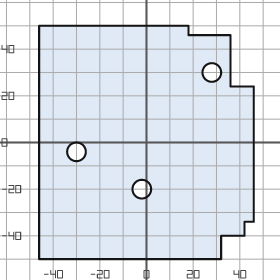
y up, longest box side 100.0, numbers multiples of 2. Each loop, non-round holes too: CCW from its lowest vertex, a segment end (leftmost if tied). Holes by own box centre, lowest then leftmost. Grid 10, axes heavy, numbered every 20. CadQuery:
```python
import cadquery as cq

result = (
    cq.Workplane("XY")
    .moveTo(-46.0, -50.0)
    .lineTo(32.0, -50.0)
    .lineTo(32.0, -40.0)
    .lineTo(42.0, -40.0)
    .lineTo(42.0, -34.0)
    .lineTo(46.0, -34.0)
    .lineTo(46.0, 24.0)
    .lineTo(36.0, 24.0)
    .lineTo(36.0, 46.0)
    .lineTo(18.0, 46.0)
    .lineTo(18.0, 50.0)
    .lineTo(-46.0, 50.0)
    .close()
    .moveTo(-2.0, -20.0)
    .circle(4.0)
    .moveTo(-30.0, -4.0)
    .circle(4.0)
    .moveTo(28.0, 30.0)
    .circle(4.0)
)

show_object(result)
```